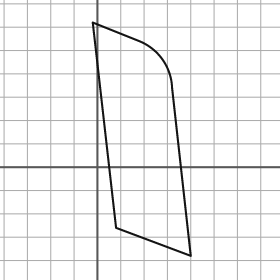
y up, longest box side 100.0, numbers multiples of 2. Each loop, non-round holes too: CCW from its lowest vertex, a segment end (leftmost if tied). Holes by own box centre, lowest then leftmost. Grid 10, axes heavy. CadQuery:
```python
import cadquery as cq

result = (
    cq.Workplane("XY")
    .moveTo(40.0, -38.0)
    .lineTo(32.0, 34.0)
    .threePointArc((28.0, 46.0), (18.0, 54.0))
    .lineTo(-2.0, 62.0)
    .lineTo(8.0, -26.0)
    .close()
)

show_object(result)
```